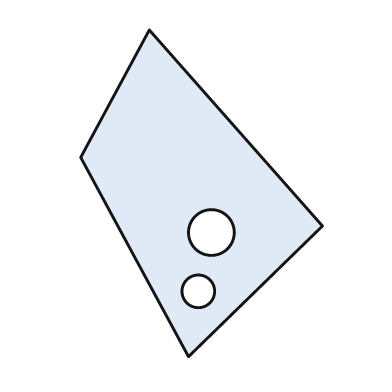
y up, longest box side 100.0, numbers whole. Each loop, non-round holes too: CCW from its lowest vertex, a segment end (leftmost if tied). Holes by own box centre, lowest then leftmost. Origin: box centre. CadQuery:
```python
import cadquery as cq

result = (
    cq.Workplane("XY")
    .moveTo(-4.0, -50.0)
    .lineTo(37.0, -10.0)
    .lineTo(-16.0, 50.0)
    .lineTo(-37.0, 11.0)
    .close()
    .moveTo(-1.0, -30.0)
    .circle(5.0)
    .moveTo(3.0, -12.0)
    .circle(7.0)
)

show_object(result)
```